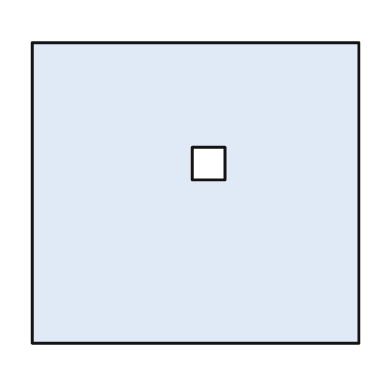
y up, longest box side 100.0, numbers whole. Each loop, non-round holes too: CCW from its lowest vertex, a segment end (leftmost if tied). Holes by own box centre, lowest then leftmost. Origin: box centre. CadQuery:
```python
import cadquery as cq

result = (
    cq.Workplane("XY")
    .moveTo(-50.0, -46.0)
    .lineTo(50.0, -46.0)
    .lineTo(50.0, 46.0)
    .lineTo(-50.0, 46.0)
    .close()
    .moveTo(-1.0, 4.0)
    .lineTo(9.0, 4.0)
    .lineTo(9.0, 14.0)
    .lineTo(-1.0, 14.0)
    .close()
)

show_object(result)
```